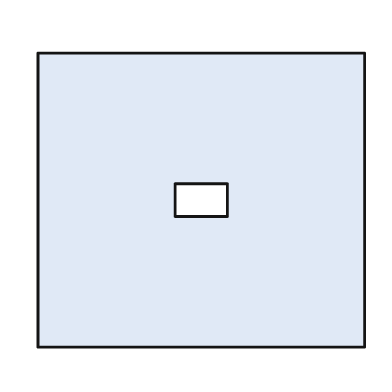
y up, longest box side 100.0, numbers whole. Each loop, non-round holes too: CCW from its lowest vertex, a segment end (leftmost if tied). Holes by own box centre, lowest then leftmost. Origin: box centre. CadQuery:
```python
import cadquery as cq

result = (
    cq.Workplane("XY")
    .moveTo(-50.0, -45.0)
    .lineTo(50.0, -45.0)
    .lineTo(50.0, 45.0)
    .lineTo(-50.0, 45.0)
    .close()
    .moveTo(-8.0, -5.0)
    .lineTo(8.0, -5.0)
    .lineTo(8.0, 5.0)
    .lineTo(-8.0, 5.0)
    .close()
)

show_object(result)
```